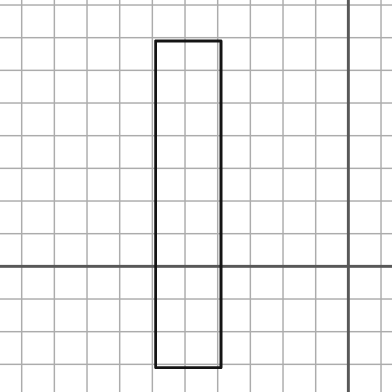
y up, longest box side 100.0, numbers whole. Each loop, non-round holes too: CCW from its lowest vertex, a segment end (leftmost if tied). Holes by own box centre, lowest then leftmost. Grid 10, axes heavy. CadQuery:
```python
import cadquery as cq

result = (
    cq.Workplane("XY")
    .moveTo(-59.0, -31.0)
    .lineTo(-39.0, -31.0)
    .lineTo(-39.0, 69.0)
    .lineTo(-59.0, 69.0)
    .close()
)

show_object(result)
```